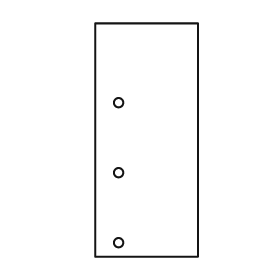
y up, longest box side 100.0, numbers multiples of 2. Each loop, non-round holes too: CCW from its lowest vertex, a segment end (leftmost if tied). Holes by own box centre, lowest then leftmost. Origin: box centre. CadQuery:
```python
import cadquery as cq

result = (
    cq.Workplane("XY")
    .moveTo(-22.0, -50.0)
    .lineTo(22.0, -50.0)
    .lineTo(22.0, 50.0)
    .lineTo(-22.0, 50.0)
    .close()
    .moveTo(-12.0, -44.0)
    .circle(2.0)
    .moveTo(-12.0, -14.0)
    .circle(2.0)
    .moveTo(-12.0, 16.0)
    .circle(2.0)
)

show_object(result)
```